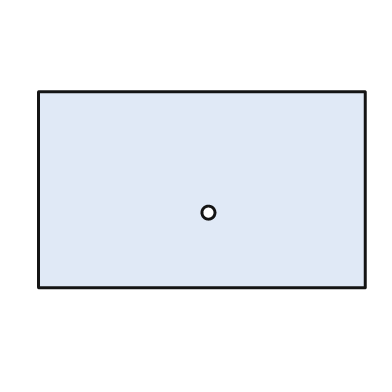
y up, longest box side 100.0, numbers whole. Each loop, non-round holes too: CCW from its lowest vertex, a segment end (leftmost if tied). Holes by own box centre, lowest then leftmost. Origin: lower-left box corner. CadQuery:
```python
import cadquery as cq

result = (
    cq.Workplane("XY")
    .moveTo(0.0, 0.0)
    .lineTo(100.0, 0.0)
    .lineTo(100.0, 60.0)
    .lineTo(0.0, 60.0)
    .close()
    .moveTo(52.0, 23.0)
    .circle(2.0)
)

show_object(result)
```